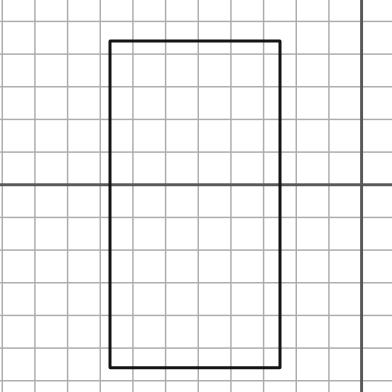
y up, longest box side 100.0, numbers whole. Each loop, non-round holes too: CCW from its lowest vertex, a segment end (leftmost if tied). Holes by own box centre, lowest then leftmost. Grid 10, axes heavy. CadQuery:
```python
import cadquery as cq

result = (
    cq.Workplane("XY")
    .moveTo(-77.0, -56.0)
    .lineTo(-25.0, -56.0)
    .lineTo(-25.0, 44.0)
    .lineTo(-77.0, 44.0)
    .close()
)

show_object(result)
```